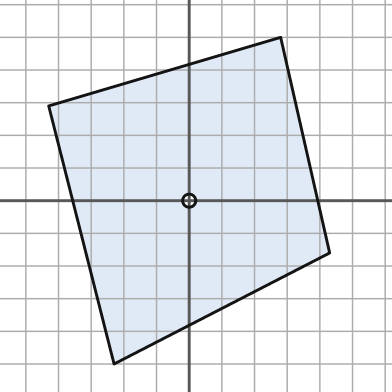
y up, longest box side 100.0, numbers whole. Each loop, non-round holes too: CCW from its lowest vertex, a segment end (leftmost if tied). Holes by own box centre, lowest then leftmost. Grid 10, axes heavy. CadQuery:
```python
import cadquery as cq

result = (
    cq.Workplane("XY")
    .moveTo(-23.0, -50.0)
    .lineTo(43.0, -16.0)
    .lineTo(28.0, 50.0)
    .lineTo(-43.0, 29.0)
    .close()
    .moveTo(0.0, 0.0)
    .circle(2.0)
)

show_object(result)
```